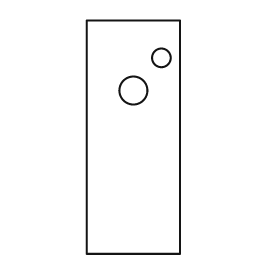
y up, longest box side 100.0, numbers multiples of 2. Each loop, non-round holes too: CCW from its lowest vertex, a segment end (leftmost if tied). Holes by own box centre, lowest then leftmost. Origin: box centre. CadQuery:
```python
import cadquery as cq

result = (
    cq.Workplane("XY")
    .moveTo(-20.0, -50.0)
    .lineTo(20.0, -50.0)
    .lineTo(20.0, 50.0)
    .lineTo(-20.0, 50.0)
    .close()
    .moveTo(0.0, 20.0)
    .circle(6.0)
    .moveTo(12.0, 34.0)
    .circle(4.0)
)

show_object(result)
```